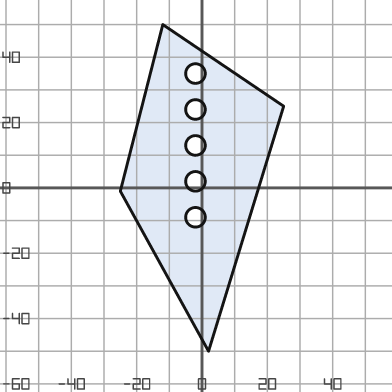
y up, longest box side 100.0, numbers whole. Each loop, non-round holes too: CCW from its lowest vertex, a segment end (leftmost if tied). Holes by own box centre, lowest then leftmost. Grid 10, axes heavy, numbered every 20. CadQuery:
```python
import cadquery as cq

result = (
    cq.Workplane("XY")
    .moveTo(2.0, -50.0)
    .lineTo(25.0, 25.0)
    .lineTo(-12.0, 50.0)
    .lineTo(-25.0, -1.0)
    .close()
    .moveTo(-2.0, -9.0)
    .circle(3.0)
    .moveTo(-2.0, 2.0)
    .circle(3.0)
    .moveTo(-2.0, 13.0)
    .circle(3.0)
    .moveTo(-2.0, 24.0)
    .circle(3.0)
    .moveTo(-2.0, 35.0)
    .circle(3.0)
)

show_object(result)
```